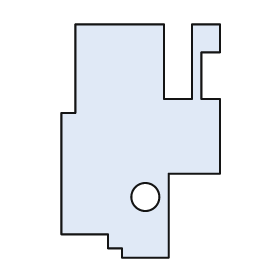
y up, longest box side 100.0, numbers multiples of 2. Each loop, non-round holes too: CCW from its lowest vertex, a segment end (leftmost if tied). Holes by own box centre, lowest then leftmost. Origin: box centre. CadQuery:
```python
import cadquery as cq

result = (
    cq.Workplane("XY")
    .moveTo(-8.0, -50.0)
    .lineTo(12.0, -50.0)
    .lineTo(12.0, -14.0)
    .lineTo(34.0, -14.0)
    .lineTo(34.0, 18.0)
    .lineTo(26.0, 18.0)
    .lineTo(26.0, 38.0)
    .lineTo(34.0, 38.0)
    .lineTo(34.0, 50.0)
    .lineTo(22.0, 50.0)
    .lineTo(22.0, 18.0)
    .lineTo(10.0, 18.0)
    .lineTo(10.0, 50.0)
    .lineTo(-28.0, 50.0)
    .lineTo(-28.0, 12.0)
    .lineTo(-34.0, 12.0)
    .lineTo(-34.0, -40.0)
    .lineTo(-14.0, -40.0)
    .lineTo(-14.0, -46.0)
    .lineTo(-8.0, -46.0)
    .close()
    .moveTo(2.0, -24.0)
    .circle(6.0)
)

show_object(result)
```